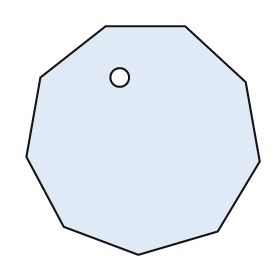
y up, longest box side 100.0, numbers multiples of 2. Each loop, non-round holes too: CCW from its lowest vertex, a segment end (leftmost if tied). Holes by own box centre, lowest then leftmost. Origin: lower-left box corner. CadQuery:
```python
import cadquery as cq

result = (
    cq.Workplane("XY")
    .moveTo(48.0, 0.0)
    .lineTo(82.0, 10.0)
    .lineTo(100.0, 40.0)
    .lineTo(94.0, 74.0)
    .lineTo(68.0, 98.0)
    .lineTo(34.0, 98.0)
    .lineTo(6.0, 76.0)
    .lineTo(0.0, 42.0)
    .lineTo(16.0, 12.0)
    .close()
    .moveTo(40.0, 76.0)
    .circle(4.0)
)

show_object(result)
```